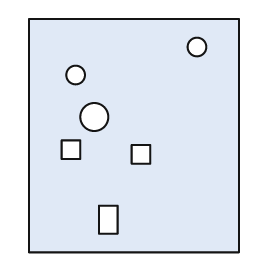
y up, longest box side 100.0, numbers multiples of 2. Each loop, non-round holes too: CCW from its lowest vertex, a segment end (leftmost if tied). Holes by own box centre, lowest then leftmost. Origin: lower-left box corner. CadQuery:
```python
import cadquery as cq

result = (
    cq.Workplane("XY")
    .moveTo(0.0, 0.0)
    .lineTo(90.0, 0.0)
    .lineTo(90.0, 100.0)
    .lineTo(0.0, 100.0)
    .close()
    .moveTo(30.0, 8.0)
    .lineTo(38.0, 8.0)
    .lineTo(38.0, 20.0)
    .lineTo(30.0, 20.0)
    .close()
    .moveTo(44.0, 38.0)
    .lineTo(52.0, 38.0)
    .lineTo(52.0, 46.0)
    .lineTo(44.0, 46.0)
    .close()
    .moveTo(14.0, 40.0)
    .lineTo(22.0, 40.0)
    .lineTo(22.0, 48.0)
    .lineTo(14.0, 48.0)
    .close()
    .moveTo(28.0, 58.0)
    .circle(6.0)
    .moveTo(20.0, 76.0)
    .circle(4.0)
    .moveTo(72.0, 88.0)
    .circle(4.0)
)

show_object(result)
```